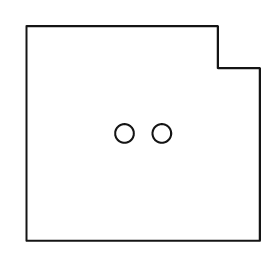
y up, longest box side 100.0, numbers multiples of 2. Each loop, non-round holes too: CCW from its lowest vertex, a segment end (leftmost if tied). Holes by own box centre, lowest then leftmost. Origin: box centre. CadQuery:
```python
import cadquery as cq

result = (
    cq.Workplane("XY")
    .moveTo(-50.0, -46.0)
    .lineTo(50.0, -46.0)
    .lineTo(50.0, 28.0)
    .lineTo(32.0, 28.0)
    .lineTo(32.0, 46.0)
    .lineTo(-50.0, 46.0)
    .close()
    .moveTo(-8.0, 0.0)
    .circle(4.0)
    .moveTo(8.0, 0.0)
    .circle(4.0)
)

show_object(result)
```